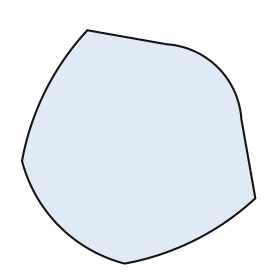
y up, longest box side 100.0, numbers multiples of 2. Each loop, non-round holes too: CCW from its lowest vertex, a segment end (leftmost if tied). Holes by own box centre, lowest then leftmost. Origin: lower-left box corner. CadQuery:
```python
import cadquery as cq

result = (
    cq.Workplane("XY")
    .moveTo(44.0, 0.0)
    .threePointArc((74.0, 10.0), (100.0, 28.0))
    .lineTo(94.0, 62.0)
    .threePointArc((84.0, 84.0), (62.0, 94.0))
    .lineTo(28.0, 100.0)
    .threePointArc((10.0, 74.0), (0.0, 44.0))
    .threePointArc((16.0, 16.0), (44.0, 0.0))
    .close()
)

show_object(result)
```